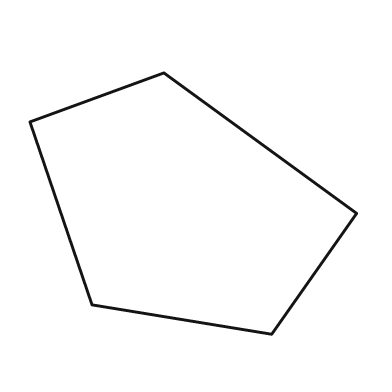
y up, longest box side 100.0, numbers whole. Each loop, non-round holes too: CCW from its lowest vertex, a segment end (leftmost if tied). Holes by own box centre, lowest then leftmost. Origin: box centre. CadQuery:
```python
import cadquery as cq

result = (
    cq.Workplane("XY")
    .moveTo(24.0, -40.0)
    .lineTo(50.0, -3.0)
    .lineTo(-9.0, 40.0)
    .lineTo(-50.0, 25.0)
    .lineTo(-31.0, -31.0)
    .close()
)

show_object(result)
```